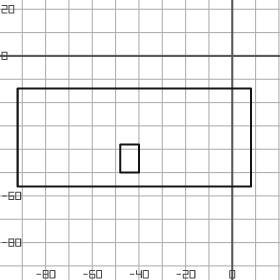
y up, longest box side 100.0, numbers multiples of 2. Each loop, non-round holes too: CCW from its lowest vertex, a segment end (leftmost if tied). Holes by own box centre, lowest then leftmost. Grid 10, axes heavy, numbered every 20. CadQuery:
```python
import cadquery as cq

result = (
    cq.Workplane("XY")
    .moveTo(-92.0, -56.0)
    .lineTo(8.0, -56.0)
    .lineTo(8.0, -14.0)
    .lineTo(-92.0, -14.0)
    .close()
    .moveTo(-48.0, -50.0)
    .lineTo(-40.0, -50.0)
    .lineTo(-40.0, -38.0)
    .lineTo(-48.0, -38.0)
    .close()
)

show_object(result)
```